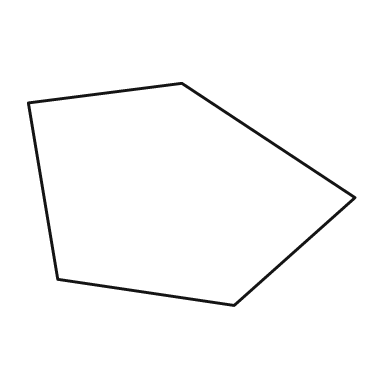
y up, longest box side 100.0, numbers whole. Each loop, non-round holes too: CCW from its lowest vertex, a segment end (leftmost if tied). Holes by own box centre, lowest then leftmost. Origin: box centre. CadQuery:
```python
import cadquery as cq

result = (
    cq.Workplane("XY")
    .moveTo(13.0, -34.0)
    .lineTo(50.0, -1.0)
    .lineTo(-3.0, 34.0)
    .lineTo(-50.0, 28.0)
    .lineTo(-41.0, -26.0)
    .close()
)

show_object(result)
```